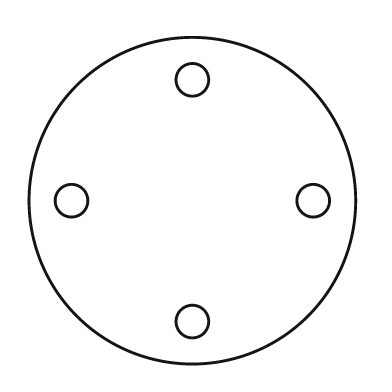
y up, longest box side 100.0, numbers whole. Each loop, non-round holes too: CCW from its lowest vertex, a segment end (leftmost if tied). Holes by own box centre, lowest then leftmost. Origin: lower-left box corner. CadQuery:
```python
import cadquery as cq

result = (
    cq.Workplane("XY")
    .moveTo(50.0, 50.0)
    .circle(50.0)
    .moveTo(50.0, 13.0)
    .circle(5.0)
    .moveTo(13.0, 50.0)
    .circle(5.0)
    .moveTo(87.0, 50.0)
    .circle(5.0)
    .moveTo(50.0, 87.0)
    .circle(5.0)
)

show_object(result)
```